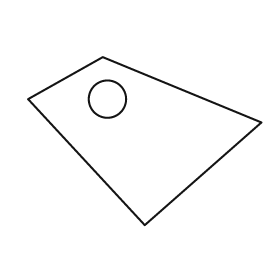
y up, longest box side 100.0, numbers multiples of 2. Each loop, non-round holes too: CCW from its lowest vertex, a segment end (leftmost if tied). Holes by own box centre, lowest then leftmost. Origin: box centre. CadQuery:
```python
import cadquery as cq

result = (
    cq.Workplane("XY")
    .moveTo(0.0, -36.0)
    .lineTo(50.0, 8.0)
    .lineTo(-18.0, 36.0)
    .lineTo(-50.0, 18.0)
    .close()
    .moveTo(-16.0, 18.0)
    .circle(8.0)
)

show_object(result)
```